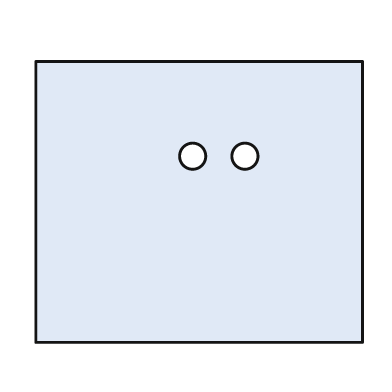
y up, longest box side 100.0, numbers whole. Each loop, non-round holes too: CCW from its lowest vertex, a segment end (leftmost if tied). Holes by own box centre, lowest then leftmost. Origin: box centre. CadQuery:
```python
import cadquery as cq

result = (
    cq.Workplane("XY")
    .moveTo(-50.0, -43.0)
    .lineTo(50.0, -43.0)
    .lineTo(50.0, 43.0)
    .lineTo(-50.0, 43.0)
    .close()
    .moveTo(-2.0, 14.0)
    .circle(4.0)
    .moveTo(14.0, 14.0)
    .circle(4.0)
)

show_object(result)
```